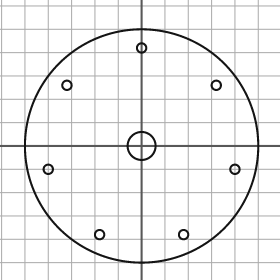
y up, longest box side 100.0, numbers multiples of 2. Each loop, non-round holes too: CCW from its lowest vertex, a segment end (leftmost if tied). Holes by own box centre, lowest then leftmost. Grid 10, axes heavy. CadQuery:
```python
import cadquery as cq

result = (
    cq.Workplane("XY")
    .moveTo(0.0, 0.0)
    .circle(50.0)
    .moveTo(-18.0, -38.0)
    .circle(2.0)
    .moveTo(18.0, -38.0)
    .circle(2.0)
    .moveTo(-40.0, -10.0)
    .circle(2.0)
    .moveTo(40.0, -10.0)
    .circle(2.0)
    .moveTo(0.0, 0.0)
    .circle(6.0)
    .moveTo(-32.0, 26.0)
    .circle(2.0)
    .moveTo(32.0, 26.0)
    .circle(2.0)
    .moveTo(0.0, 42.0)
    .circle(2.0)
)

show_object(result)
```